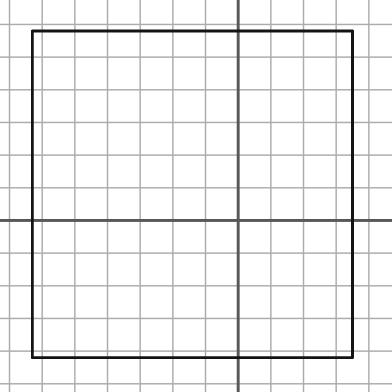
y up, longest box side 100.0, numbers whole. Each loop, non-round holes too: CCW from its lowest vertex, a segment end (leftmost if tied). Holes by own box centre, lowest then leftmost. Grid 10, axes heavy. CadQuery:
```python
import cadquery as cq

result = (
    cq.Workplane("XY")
    .moveTo(-63.0, -42.0)
    .lineTo(35.0, -42.0)
    .lineTo(35.0, 58.0)
    .lineTo(-63.0, 58.0)
    .close()
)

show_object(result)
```